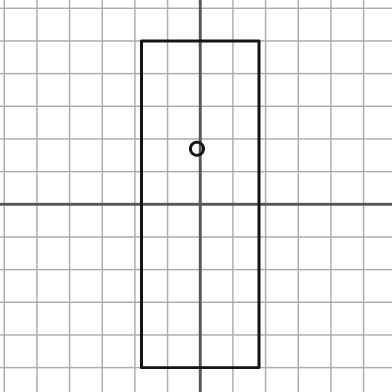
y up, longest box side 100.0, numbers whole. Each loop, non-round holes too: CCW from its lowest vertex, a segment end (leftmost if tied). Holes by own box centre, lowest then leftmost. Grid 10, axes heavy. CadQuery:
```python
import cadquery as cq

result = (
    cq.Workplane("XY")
    .moveTo(-18.0, -50.0)
    .lineTo(18.0, -50.0)
    .lineTo(18.0, 50.0)
    .lineTo(-18.0, 50.0)
    .close()
    .moveTo(-1.0, 17.0)
    .circle(2.0)
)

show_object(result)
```